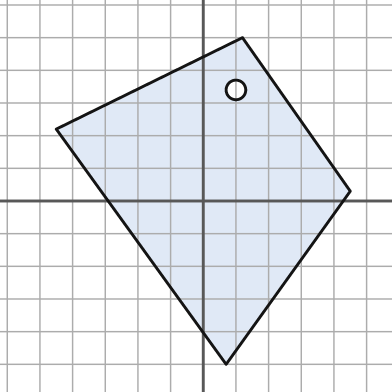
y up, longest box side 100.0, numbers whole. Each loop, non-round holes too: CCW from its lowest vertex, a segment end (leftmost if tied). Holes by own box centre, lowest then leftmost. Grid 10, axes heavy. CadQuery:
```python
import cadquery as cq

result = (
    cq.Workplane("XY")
    .moveTo(7.0, -50.0)
    .lineTo(45.0, 3.0)
    .lineTo(12.0, 50.0)
    .lineTo(-45.0, 22.0)
    .close()
    .moveTo(10.0, 34.0)
    .circle(3.0)
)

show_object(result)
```